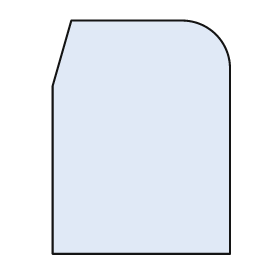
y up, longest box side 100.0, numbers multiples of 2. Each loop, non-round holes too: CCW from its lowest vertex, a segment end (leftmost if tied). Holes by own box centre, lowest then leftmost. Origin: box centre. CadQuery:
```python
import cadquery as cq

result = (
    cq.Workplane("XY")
    .moveTo(-38.0, -50.0)
    .lineTo(38.0, -50.0)
    .lineTo(38.0, 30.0)
    .threePointArc((32.0, 44.0), (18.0, 50.0))
    .lineTo(-30.0, 50.0)
    .lineTo(-38.0, 22.0)
    .close()
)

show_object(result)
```